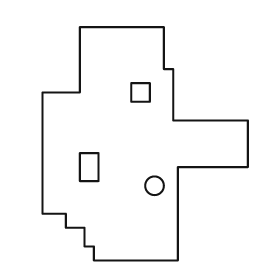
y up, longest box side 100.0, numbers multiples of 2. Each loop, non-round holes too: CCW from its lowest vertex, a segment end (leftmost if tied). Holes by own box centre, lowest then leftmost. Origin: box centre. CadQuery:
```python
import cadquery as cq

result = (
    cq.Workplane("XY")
    .moveTo(-22.0, -50.0)
    .lineTo(14.0, -50.0)
    .lineTo(14.0, -10.0)
    .lineTo(44.0, -10.0)
    .lineTo(44.0, 10.0)
    .lineTo(12.0, 10.0)
    .lineTo(12.0, 32.0)
    .lineTo(8.0, 32.0)
    .lineTo(8.0, 50.0)
    .lineTo(-28.0, 50.0)
    .lineTo(-28.0, 22.0)
    .lineTo(-44.0, 22.0)
    .lineTo(-44.0, -30.0)
    .lineTo(-34.0, -30.0)
    .lineTo(-34.0, -36.0)
    .lineTo(-26.0, -36.0)
    .lineTo(-26.0, -44.0)
    .lineTo(-22.0, -44.0)
    .close()
    .moveTo(4.0, -18.0)
    .circle(4.0)
    .moveTo(-28.0, -16.0)
    .lineTo(-20.0, -16.0)
    .lineTo(-20.0, -4.0)
    .lineTo(-28.0, -4.0)
    .close()
    .moveTo(-6.0, 18.0)
    .lineTo(2.0, 18.0)
    .lineTo(2.0, 26.0)
    .lineTo(-6.0, 26.0)
    .close()
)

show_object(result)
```